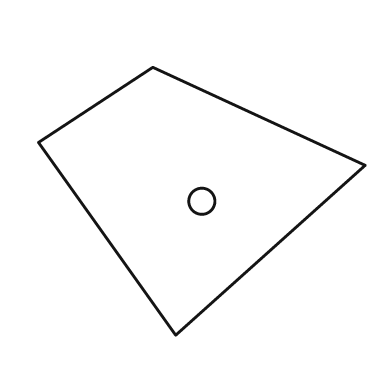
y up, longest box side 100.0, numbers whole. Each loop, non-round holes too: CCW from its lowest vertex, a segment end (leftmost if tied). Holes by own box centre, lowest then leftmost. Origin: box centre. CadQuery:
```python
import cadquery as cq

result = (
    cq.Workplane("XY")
    .moveTo(-8.0, -41.0)
    .lineTo(50.0, 11.0)
    .lineTo(-15.0, 41.0)
    .lineTo(-50.0, 18.0)
    .close()
    .moveTo(0.0, 0.0)
    .circle(4.0)
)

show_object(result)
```